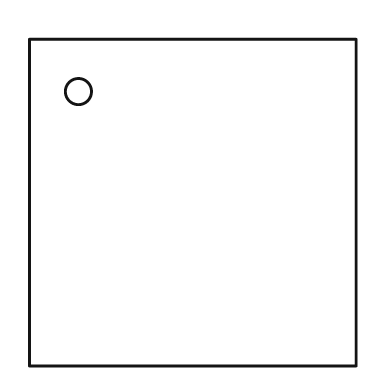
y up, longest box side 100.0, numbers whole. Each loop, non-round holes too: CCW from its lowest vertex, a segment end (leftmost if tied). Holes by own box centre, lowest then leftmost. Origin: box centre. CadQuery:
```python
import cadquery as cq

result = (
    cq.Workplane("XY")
    .moveTo(-50.0, -50.0)
    .lineTo(50.0, -50.0)
    .lineTo(50.0, 50.0)
    .lineTo(-50.0, 50.0)
    .close()
    .moveTo(-35.0, 34.0)
    .circle(4.0)
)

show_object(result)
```